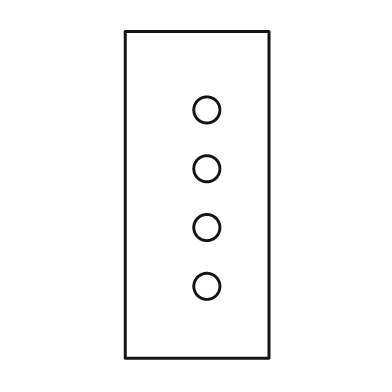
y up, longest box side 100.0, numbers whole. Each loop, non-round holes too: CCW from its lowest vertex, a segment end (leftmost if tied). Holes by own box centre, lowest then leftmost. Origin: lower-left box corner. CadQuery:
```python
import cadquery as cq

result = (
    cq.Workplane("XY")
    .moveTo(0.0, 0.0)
    .lineTo(44.0, 0.0)
    .lineTo(44.0, 100.0)
    .lineTo(0.0, 100.0)
    .close()
    .moveTo(25.0, 22.0)
    .circle(4.0)
    .moveTo(25.0, 40.0)
    .circle(4.0)
    .moveTo(25.0, 58.0)
    .circle(4.0)
    .moveTo(25.0, 76.0)
    .circle(4.0)
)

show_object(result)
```